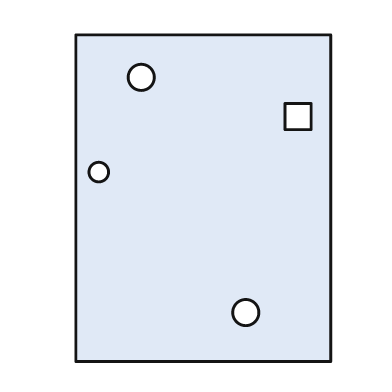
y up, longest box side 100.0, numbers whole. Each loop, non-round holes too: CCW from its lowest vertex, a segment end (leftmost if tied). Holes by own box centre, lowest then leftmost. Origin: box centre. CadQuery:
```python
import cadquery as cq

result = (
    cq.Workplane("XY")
    .moveTo(-39.0, -50.0)
    .lineTo(39.0, -50.0)
    .lineTo(39.0, 50.0)
    .lineTo(-39.0, 50.0)
    .close()
    .moveTo(13.0, -35.0)
    .circle(4.0)
    .moveTo(-32.0, 8.0)
    .circle(3.0)
    .moveTo(25.0, 21.0)
    .lineTo(33.0, 21.0)
    .lineTo(33.0, 29.0)
    .lineTo(25.0, 29.0)
    .close()
    .moveTo(-19.0, 37.0)
    .circle(4.0)
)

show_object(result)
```